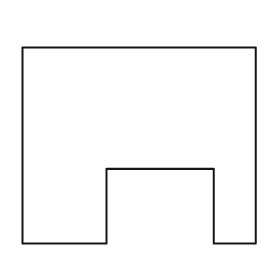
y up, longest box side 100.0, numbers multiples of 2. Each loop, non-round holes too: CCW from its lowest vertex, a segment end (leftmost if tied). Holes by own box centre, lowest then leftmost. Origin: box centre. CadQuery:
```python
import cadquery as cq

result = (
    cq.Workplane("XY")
    .moveTo(-50.0, -42.0)
    .lineTo(-14.0, -42.0)
    .lineTo(-14.0, -10.0)
    .lineTo(32.0, -10.0)
    .lineTo(32.0, -42.0)
    .lineTo(50.0, -42.0)
    .lineTo(50.0, 42.0)
    .lineTo(-50.0, 42.0)
    .close()
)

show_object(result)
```